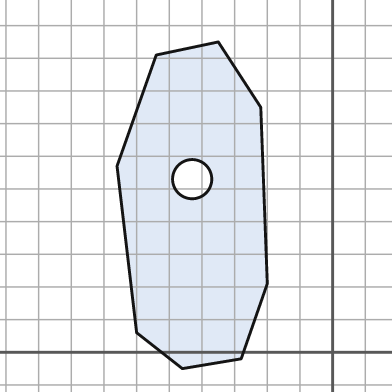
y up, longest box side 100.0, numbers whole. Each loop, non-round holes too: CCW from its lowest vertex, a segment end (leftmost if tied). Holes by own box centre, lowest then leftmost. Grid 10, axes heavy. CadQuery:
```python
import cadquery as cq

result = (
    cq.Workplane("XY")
    .moveTo(-46.0, -5.0)
    .lineTo(-28.0, -2.0)
    .lineTo(-20.0, 21.0)
    .lineTo(-22.0, 75.0)
    .lineTo(-35.0, 95.0)
    .lineTo(-54.0, 91.0)
    .lineTo(-66.0, 57.0)
    .lineTo(-60.0, 6.0)
    .close()
    .moveTo(-43.0, 53.0)
    .circle(6.0)
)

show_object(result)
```